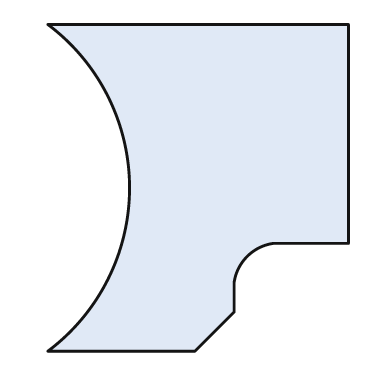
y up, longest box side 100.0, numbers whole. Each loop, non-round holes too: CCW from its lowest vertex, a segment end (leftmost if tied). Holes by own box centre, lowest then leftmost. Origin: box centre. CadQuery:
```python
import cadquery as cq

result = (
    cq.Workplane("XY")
    .moveTo(-46.0, -50.0)
    .lineTo(-1.0, -50.0)
    .lineTo(11.0, -38.0)
    .lineTo(11.0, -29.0)
    .threePointArc((15.0, -21.0), (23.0, -17.0))
    .lineTo(46.0, -17.0)
    .lineTo(46.0, 50.0)
    .lineTo(-46.0, 50.0)
    .threePointArc((-21.0, 0.0), (-46.0, -50.0))
    .close()
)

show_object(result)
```